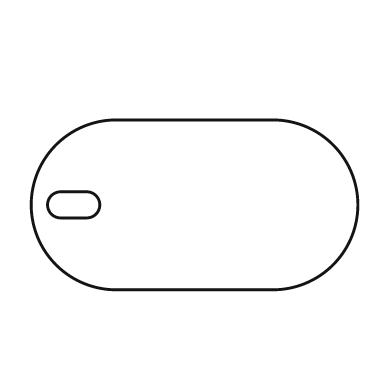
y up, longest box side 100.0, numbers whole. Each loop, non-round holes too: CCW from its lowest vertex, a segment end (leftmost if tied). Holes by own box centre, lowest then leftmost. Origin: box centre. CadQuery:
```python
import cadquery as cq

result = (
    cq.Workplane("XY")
    .moveTo(-24.0, -26.0)
    .lineTo(24.0, -26.0)
    .threePointArc((50.0, 0.0), (24.0, 26.0))
    .lineTo(-24.0, 26.0)
    .threePointArc((-50.0, 0.0), (-24.0, -26.0))
    .close()
    .moveTo(-41.0, -4.0)
    .lineTo(-33.0, -4.0)
    .threePointArc((-29.0, 0.0), (-33.0, 4.0))
    .lineTo(-41.0, 4.0)
    .threePointArc((-45.0, 0.0), (-41.0, -4.0))
    .close()
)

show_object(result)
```